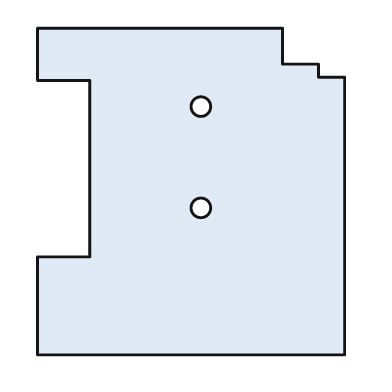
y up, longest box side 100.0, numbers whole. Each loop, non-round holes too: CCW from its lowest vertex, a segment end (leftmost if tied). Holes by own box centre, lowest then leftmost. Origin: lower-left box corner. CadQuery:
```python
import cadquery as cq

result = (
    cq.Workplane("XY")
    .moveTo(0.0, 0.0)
    .lineTo(94.0, 0.0)
    .lineTo(94.0, 85.0)
    .lineTo(86.0, 85.0)
    .lineTo(86.0, 89.0)
    .lineTo(75.0, 89.0)
    .lineTo(75.0, 100.0)
    .lineTo(0.0, 100.0)
    .lineTo(0.0, 84.0)
    .lineTo(16.0, 84.0)
    .lineTo(16.0, 30.0)
    .lineTo(0.0, 30.0)
    .close()
    .moveTo(50.0, 45.0)
    .circle(3.0)
    .moveTo(50.0, 76.0)
    .circle(3.0)
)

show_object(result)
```